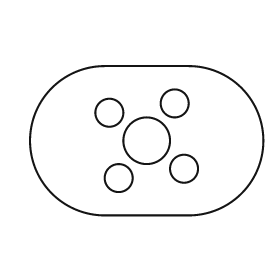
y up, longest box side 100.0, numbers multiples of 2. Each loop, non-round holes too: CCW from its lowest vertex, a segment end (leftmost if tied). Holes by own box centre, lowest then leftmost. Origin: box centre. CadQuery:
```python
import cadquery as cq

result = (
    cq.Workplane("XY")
    .moveTo(-18.0, -32.0)
    .lineTo(18.0, -32.0)
    .threePointArc((50.0, 0.0), (18.0, 32.0))
    .lineTo(-18.0, 32.0)
    .threePointArc((-50.0, 0.0), (-18.0, -32.0))
    .close()
    .moveTo(-12.0, -16.0)
    .circle(6.0)
    .moveTo(16.0, -12.0)
    .circle(6.0)
    .moveTo(0.0, 0.0)
    .circle(10.0)
    .moveTo(-16.0, 12.0)
    .circle(6.0)
    .moveTo(12.0, 16.0)
    .circle(6.0)
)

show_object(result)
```